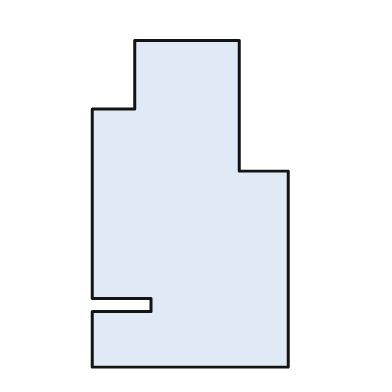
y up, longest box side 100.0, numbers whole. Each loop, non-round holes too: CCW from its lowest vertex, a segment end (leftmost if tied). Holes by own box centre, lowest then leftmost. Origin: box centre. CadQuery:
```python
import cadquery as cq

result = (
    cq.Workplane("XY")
    .moveTo(-30.0, -50.0)
    .lineTo(30.0, -50.0)
    .lineTo(30.0, 10.0)
    .lineTo(15.0, 10.0)
    .lineTo(15.0, 50.0)
    .lineTo(-17.0, 50.0)
    .lineTo(-17.0, 29.0)
    .lineTo(-30.0, 29.0)
    .lineTo(-30.0, -29.0)
    .lineTo(-12.0, -29.0)
    .lineTo(-12.0, -33.0)
    .lineTo(-30.0, -33.0)
    .close()
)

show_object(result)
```